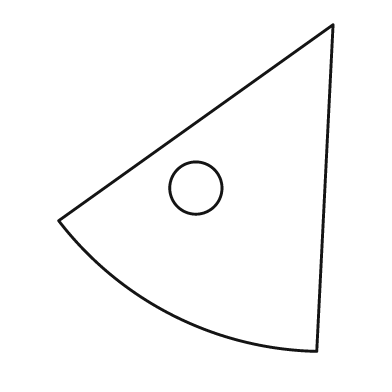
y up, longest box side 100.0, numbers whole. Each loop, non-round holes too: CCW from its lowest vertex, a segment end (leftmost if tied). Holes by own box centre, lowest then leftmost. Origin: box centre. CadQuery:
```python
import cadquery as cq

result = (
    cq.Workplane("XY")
    .moveTo(37.0, -50.0)
    .lineTo(42.0, 50.0)
    .lineTo(-42.0, -10.0)
    .threePointArc((-7.0, -39.0), (37.0, -50.0))
    .close()
    .moveTo(0.0, 0.0)
    .circle(8.0)
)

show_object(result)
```